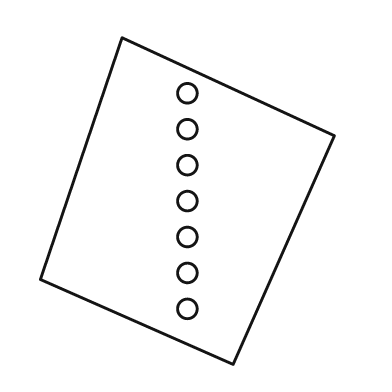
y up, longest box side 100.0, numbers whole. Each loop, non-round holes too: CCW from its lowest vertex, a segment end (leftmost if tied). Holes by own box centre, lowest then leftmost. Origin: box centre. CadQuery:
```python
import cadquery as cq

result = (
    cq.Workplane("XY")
    .moveTo(14.0, -50.0)
    .lineTo(45.0, 20.0)
    .lineTo(-20.0, 50.0)
    .lineTo(-45.0, -24.0)
    .close()
    .moveTo(0.0, -33.0)
    .circle(3.0)
    .moveTo(0.0, -22.0)
    .circle(3.0)
    .moveTo(0.0, -11.0)
    .circle(3.0)
    .moveTo(0.0, 0.0)
    .circle(3.0)
    .moveTo(0.0, 11.0)
    .circle(3.0)
    .moveTo(0.0, 22.0)
    .circle(3.0)
    .moveTo(0.0, 33.0)
    .circle(3.0)
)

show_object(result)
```